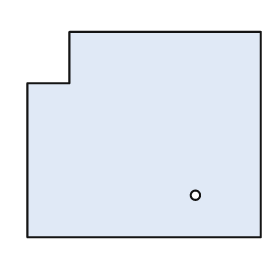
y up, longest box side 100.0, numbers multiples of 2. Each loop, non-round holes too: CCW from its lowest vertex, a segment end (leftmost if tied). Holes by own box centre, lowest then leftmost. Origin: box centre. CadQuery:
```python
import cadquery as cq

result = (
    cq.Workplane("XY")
    .moveTo(-50.0, -44.0)
    .lineTo(50.0, -44.0)
    .lineTo(50.0, 44.0)
    .lineTo(-32.0, 44.0)
    .lineTo(-32.0, 22.0)
    .lineTo(-50.0, 22.0)
    .close()
    .moveTo(22.0, -26.0)
    .circle(2.0)
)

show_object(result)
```